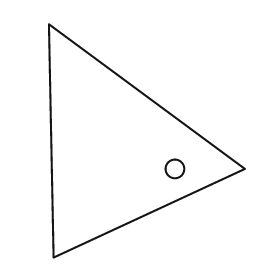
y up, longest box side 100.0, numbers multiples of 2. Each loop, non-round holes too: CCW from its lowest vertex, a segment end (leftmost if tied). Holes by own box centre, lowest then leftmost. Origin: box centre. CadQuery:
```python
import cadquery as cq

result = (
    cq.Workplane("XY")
    .moveTo(-40.0, -50.0)
    .lineTo(42.0, -12.0)
    .lineTo(-42.0, 50.0)
    .close()
    .moveTo(12.0, -12.0)
    .circle(4.0)
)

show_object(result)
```